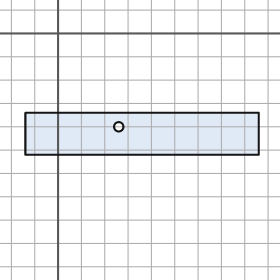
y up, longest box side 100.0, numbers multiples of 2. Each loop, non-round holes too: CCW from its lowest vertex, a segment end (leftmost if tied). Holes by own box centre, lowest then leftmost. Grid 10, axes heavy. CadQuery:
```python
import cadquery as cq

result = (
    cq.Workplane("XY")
    .moveTo(-14.0, -52.0)
    .lineTo(86.0, -52.0)
    .lineTo(86.0, -34.0)
    .lineTo(-14.0, -34.0)
    .close()
    .moveTo(26.0, -40.0)
    .circle(2.0)
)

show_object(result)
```